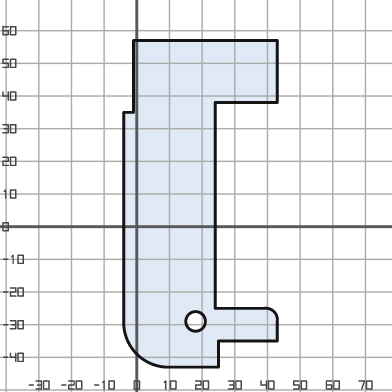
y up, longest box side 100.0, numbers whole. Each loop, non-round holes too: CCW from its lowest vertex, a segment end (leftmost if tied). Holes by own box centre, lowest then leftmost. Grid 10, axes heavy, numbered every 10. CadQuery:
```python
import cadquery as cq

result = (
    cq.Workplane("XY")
    .moveTo(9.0, -43.0)
    .lineTo(25.0, -43.0)
    .lineTo(25.0, -35.0)
    .lineTo(43.0, -35.0)
    .lineTo(43.0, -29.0)
    .threePointArc((42.0, -26.0), (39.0, -25.0))
    .lineTo(24.0, -25.0)
    .lineTo(24.0, 38.0)
    .lineTo(43.0, 38.0)
    .lineTo(43.0, 57.0)
    .lineTo(-1.0, 57.0)
    .lineTo(-1.0, 35.0)
    .lineTo(-4.0, 35.0)
    .lineTo(-4.0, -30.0)
    .threePointArc((0.0, -39.0), (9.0, -43.0))
    .close()
    .moveTo(18.0, -29.0)
    .circle(3.0)
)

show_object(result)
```